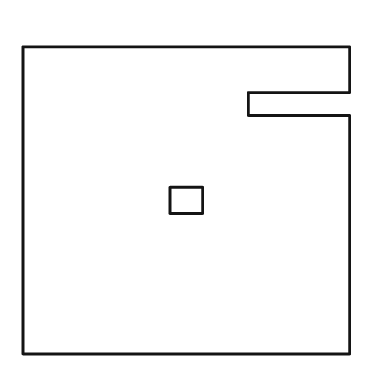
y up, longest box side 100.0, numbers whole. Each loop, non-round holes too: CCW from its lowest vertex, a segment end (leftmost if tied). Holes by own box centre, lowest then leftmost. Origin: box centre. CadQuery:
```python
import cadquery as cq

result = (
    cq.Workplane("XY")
    .moveTo(-50.0, -47.0)
    .lineTo(50.0, -47.0)
    .lineTo(50.0, 26.0)
    .lineTo(19.0, 26.0)
    .lineTo(19.0, 33.0)
    .lineTo(50.0, 33.0)
    .lineTo(50.0, 47.0)
    .lineTo(-50.0, 47.0)
    .close()
    .moveTo(-5.0, -4.0)
    .lineTo(5.0, -4.0)
    .lineTo(5.0, 4.0)
    .lineTo(-5.0, 4.0)
    .close()
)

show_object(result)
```